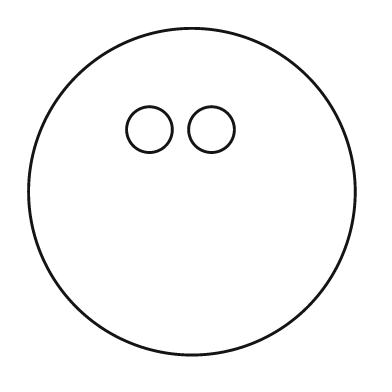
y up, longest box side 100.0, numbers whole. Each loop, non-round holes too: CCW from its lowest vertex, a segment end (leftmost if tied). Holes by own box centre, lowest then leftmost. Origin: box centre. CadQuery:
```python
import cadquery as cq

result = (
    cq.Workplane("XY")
    .moveTo(0.0, 0.0)
    .circle(50.0)
    .moveTo(-13.0, 19.0)
    .circle(7.0)
    .moveTo(6.0, 19.0)
    .circle(7.0)
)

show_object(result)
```